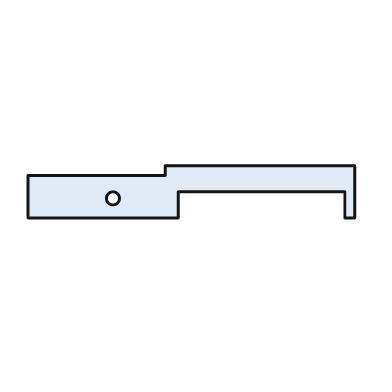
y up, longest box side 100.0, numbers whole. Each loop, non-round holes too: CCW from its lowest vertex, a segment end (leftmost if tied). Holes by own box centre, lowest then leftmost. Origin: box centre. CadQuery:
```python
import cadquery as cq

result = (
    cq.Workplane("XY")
    .moveTo(-50.0, -8.0)
    .lineTo(-4.0, -8.0)
    .lineTo(-4.0, 0.0)
    .lineTo(47.0, 0.0)
    .lineTo(47.0, -8.0)
    .lineTo(50.0, -8.0)
    .lineTo(50.0, 8.0)
    .lineTo(-8.0, 8.0)
    .lineTo(-8.0, 5.0)
    .lineTo(-50.0, 5.0)
    .close()
    .moveTo(-24.0, -2.0)
    .circle(2.0)
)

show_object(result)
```